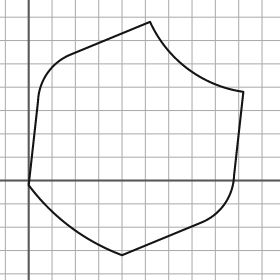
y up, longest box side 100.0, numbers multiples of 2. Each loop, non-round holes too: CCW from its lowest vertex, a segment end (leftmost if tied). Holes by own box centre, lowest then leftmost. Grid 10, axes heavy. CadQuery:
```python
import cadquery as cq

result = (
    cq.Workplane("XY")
    .moveTo(40.0, -32.0)
    .lineTo(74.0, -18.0)
    .threePointArc((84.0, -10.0), (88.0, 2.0))
    .lineTo(92.0, 38.0)
    .threePointArc((68.0, 48.0), (52.0, 68.0))
    .lineTo(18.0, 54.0)
    .threePointArc((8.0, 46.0), (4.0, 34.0))
    .lineTo(0.0, -2.0)
    .threePointArc((18.0, -20.0), (40.0, -32.0))
    .close()
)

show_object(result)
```